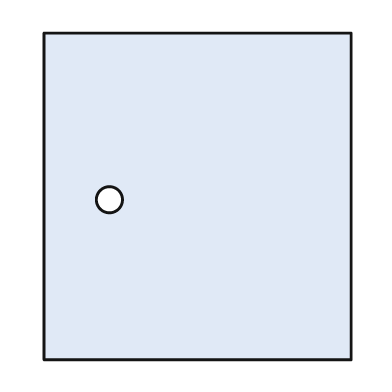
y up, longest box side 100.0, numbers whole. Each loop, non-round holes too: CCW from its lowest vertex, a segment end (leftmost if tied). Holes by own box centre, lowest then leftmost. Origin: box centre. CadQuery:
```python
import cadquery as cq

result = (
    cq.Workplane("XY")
    .moveTo(-47.0, -50.0)
    .lineTo(47.0, -50.0)
    .lineTo(47.0, 50.0)
    .lineTo(-47.0, 50.0)
    .close()
    .moveTo(-27.0, -1.0)
    .circle(4.0)
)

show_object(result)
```